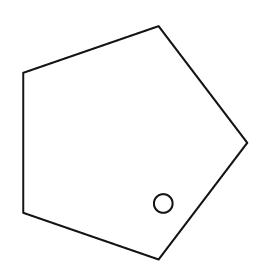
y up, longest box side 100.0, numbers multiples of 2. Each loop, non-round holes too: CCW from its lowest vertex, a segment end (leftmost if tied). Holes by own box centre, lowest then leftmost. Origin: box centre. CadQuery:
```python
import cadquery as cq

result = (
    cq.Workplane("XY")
    .moveTo(10.0, -50.0)
    .lineTo(48.0, 0.0)
    .lineTo(10.0, 50.0)
    .lineTo(-48.0, 30.0)
    .lineTo(-48.0, -30.0)
    .close()
    .moveTo(12.0, -26.0)
    .circle(4.0)
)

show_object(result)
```